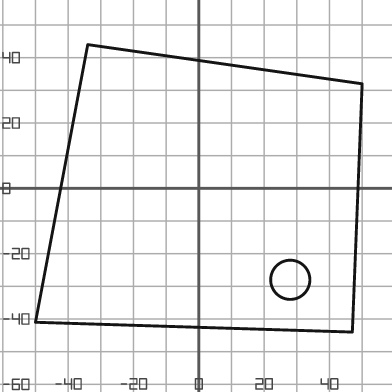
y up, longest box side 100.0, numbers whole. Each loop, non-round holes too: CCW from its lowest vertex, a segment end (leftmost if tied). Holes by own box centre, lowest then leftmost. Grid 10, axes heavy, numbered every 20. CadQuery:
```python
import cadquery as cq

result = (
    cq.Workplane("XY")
    .moveTo(47.0, -44.0)
    .lineTo(50.0, 32.0)
    .lineTo(-34.0, 44.0)
    .lineTo(-50.0, -41.0)
    .close()
    .moveTo(28.0, -28.0)
    .circle(6.0)
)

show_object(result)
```